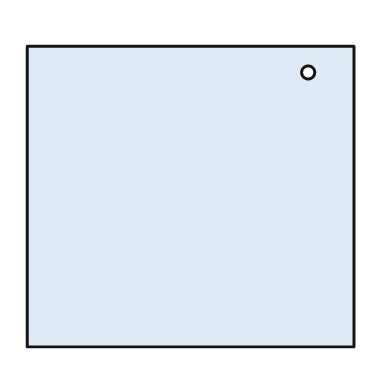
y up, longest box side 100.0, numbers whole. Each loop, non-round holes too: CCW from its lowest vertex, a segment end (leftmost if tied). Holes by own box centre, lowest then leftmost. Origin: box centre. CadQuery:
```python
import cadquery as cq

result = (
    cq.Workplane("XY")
    .moveTo(-50.0, -46.0)
    .lineTo(50.0, -46.0)
    .lineTo(50.0, 46.0)
    .lineTo(-50.0, 46.0)
    .close()
    .moveTo(36.0, 38.0)
    .circle(2.0)
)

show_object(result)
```